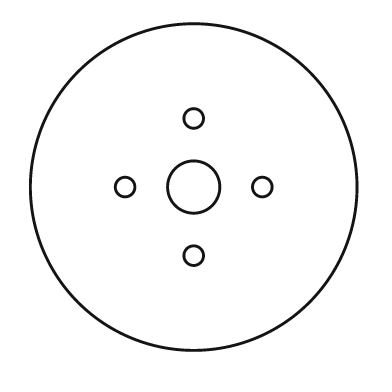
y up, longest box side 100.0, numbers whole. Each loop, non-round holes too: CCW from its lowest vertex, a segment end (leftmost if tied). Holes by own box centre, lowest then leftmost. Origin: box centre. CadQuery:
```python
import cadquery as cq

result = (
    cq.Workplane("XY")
    .moveTo(0.0, 0.0)
    .circle(50.0)
    .moveTo(0.0, -21.0)
    .circle(3.0)
    .moveTo(-21.0, 0.0)
    .circle(3.0)
    .moveTo(0.0, 0.0)
    .circle(8.0)
    .moveTo(21.0, 0.0)
    .circle(3.0)
    .moveTo(0.0, 21.0)
    .circle(3.0)
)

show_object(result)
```